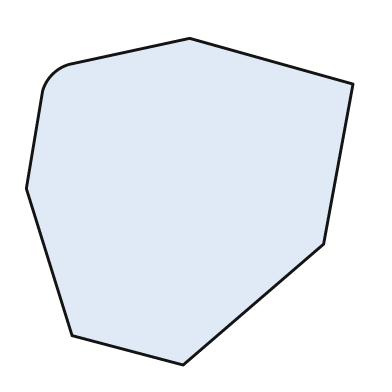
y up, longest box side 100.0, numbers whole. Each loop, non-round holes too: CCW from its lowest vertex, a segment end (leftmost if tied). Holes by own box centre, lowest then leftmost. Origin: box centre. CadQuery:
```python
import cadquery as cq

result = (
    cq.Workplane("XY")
    .moveTo(-2.0, -50.0)
    .lineTo(41.0, -13.0)
    .lineTo(50.0, 36.0)
    .lineTo(0.0, 50.0)
    .lineTo(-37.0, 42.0)
    .threePointArc((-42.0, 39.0), (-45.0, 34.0))
    .lineTo(-50.0, 4.0)
    .lineTo(-36.0, -41.0)
    .close()
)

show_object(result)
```